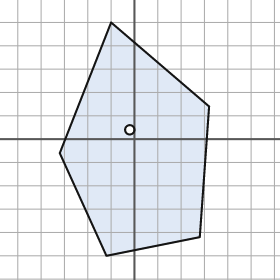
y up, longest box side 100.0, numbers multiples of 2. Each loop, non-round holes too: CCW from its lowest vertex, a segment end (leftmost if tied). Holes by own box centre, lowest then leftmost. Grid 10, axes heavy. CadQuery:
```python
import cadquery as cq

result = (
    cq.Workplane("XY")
    .moveTo(-12.0, -50.0)
    .lineTo(28.0, -42.0)
    .lineTo(32.0, 14.0)
    .lineTo(-10.0, 50.0)
    .lineTo(-32.0, -6.0)
    .close()
    .moveTo(-2.0, 4.0)
    .circle(2.0)
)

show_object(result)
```